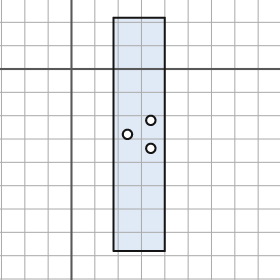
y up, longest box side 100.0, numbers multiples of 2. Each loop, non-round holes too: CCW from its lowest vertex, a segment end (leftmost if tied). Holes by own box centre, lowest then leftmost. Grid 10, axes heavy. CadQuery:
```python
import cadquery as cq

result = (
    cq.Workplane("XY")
    .moveTo(18.0, -78.0)
    .lineTo(40.0, -78.0)
    .lineTo(40.0, 22.0)
    .lineTo(18.0, 22.0)
    .close()
    .moveTo(34.0, -34.0)
    .circle(2.0)
    .moveTo(24.0, -28.0)
    .circle(2.0)
    .moveTo(34.0, -22.0)
    .circle(2.0)
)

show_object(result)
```